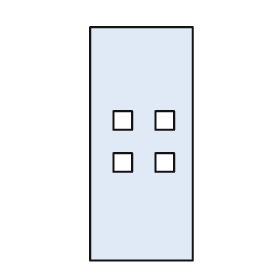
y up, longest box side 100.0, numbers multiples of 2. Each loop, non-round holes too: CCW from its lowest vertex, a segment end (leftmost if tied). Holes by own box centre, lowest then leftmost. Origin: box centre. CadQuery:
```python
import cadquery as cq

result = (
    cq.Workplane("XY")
    .moveTo(-22.0, -50.0)
    .lineTo(22.0, -50.0)
    .lineTo(22.0, 50.0)
    .lineTo(-22.0, 50.0)
    .close()
    .moveTo(-12.0, -12.0)
    .lineTo(-4.0, -12.0)
    .lineTo(-4.0, -4.0)
    .lineTo(-12.0, -4.0)
    .close()
    .moveTo(6.0, -12.0)
    .lineTo(14.0, -12.0)
    .lineTo(14.0, -4.0)
    .lineTo(6.0, -4.0)
    .close()
    .moveTo(-12.0, 6.0)
    .lineTo(-4.0, 6.0)
    .lineTo(-4.0, 14.0)
    .lineTo(-12.0, 14.0)
    .close()
    .moveTo(6.0, 6.0)
    .lineTo(14.0, 6.0)
    .lineTo(14.0, 14.0)
    .lineTo(6.0, 14.0)
    .close()
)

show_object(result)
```